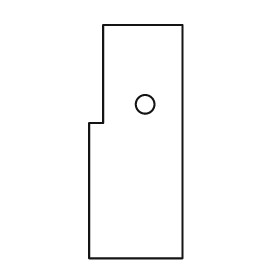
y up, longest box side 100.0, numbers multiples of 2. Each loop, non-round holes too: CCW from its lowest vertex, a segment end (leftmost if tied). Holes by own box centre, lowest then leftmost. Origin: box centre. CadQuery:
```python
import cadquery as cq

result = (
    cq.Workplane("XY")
    .moveTo(-20.0, -50.0)
    .lineTo(20.0, -50.0)
    .lineTo(20.0, 50.0)
    .lineTo(-14.0, 50.0)
    .lineTo(-14.0, 8.0)
    .lineTo(-20.0, 8.0)
    .close()
    .moveTo(4.0, 16.0)
    .circle(4.0)
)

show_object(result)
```